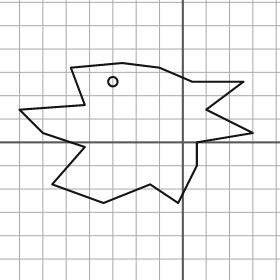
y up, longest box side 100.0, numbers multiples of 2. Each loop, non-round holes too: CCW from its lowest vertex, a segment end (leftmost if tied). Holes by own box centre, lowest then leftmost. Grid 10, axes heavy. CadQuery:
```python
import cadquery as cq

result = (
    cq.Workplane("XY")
    .moveTo(-34.0, -26.0)
    .lineTo(-14.0, -18.0)
    .lineTo(-2.0, -26.0)
    .lineTo(6.0, -10.0)
    .lineTo(6.0, 0.0)
    .lineTo(30.0, 4.0)
    .lineTo(10.0, 14.0)
    .lineTo(26.0, 26.0)
    .lineTo(4.0, 26.0)
    .lineTo(-10.0, 32.0)
    .lineTo(-26.0, 34.0)
    .lineTo(-48.0, 32.0)
    .lineTo(-42.0, 16.0)
    .lineTo(-70.0, 14.0)
    .lineTo(-60.0, 4.0)
    .lineTo(-42.0, -2.0)
    .lineTo(-56.0, -18.0)
    .close()
    .moveTo(-30.0, 26.0)
    .circle(2.0)
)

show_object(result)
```